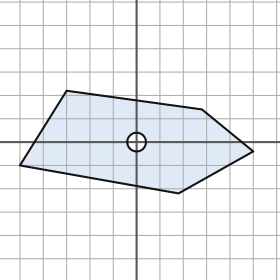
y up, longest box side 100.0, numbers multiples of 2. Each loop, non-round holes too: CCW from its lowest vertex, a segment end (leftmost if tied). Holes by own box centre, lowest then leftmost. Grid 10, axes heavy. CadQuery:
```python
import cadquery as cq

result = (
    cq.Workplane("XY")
    .moveTo(18.0, -22.0)
    .lineTo(50.0, -4.0)
    .lineTo(28.0, 14.0)
    .lineTo(-30.0, 22.0)
    .lineTo(-50.0, -10.0)
    .close()
    .moveTo(0.0, 0.0)
    .circle(4.0)
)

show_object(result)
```